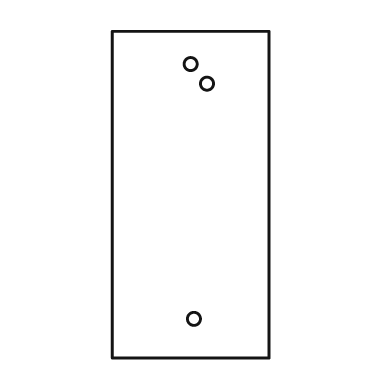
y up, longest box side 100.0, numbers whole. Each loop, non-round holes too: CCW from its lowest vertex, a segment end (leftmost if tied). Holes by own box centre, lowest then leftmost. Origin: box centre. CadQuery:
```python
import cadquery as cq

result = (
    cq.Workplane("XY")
    .moveTo(-24.0, -50.0)
    .lineTo(24.0, -50.0)
    .lineTo(24.0, 50.0)
    .lineTo(-24.0, 50.0)
    .close()
    .moveTo(1.0, -38.0)
    .circle(2.0)
    .moveTo(5.0, 34.0)
    .circle(2.0)
    .moveTo(0.0, 40.0)
    .circle(2.0)
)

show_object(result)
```